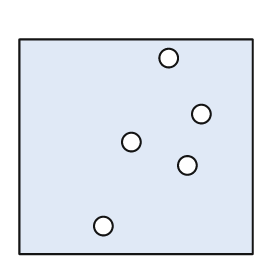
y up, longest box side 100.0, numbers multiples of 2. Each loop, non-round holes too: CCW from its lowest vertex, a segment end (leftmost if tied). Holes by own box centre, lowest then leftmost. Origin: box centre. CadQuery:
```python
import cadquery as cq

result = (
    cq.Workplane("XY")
    .moveTo(-50.0, -46.0)
    .lineTo(50.0, -46.0)
    .lineTo(50.0, 46.0)
    .lineTo(-50.0, 46.0)
    .close()
    .moveTo(-14.0, -34.0)
    .circle(4.0)
    .moveTo(22.0, -8.0)
    .circle(4.0)
    .moveTo(-2.0, 2.0)
    .circle(4.0)
    .moveTo(28.0, 14.0)
    .circle(4.0)
    .moveTo(14.0, 38.0)
    .circle(4.0)
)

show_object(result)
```